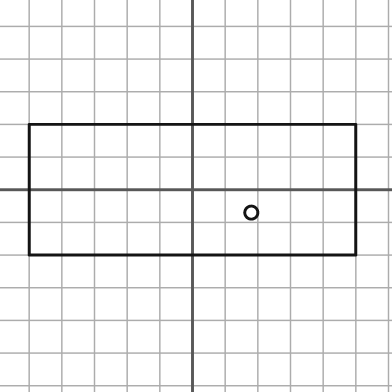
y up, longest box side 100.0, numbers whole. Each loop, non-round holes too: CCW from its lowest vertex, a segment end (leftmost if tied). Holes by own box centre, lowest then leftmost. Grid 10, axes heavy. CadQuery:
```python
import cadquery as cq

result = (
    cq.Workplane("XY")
    .moveTo(-50.0, -20.0)
    .lineTo(50.0, -20.0)
    .lineTo(50.0, 20.0)
    .lineTo(-50.0, 20.0)
    .close()
    .moveTo(18.0, -7.0)
    .circle(2.0)
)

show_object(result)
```